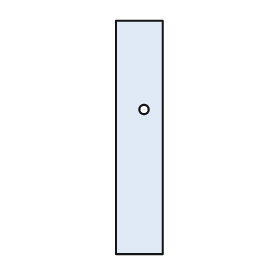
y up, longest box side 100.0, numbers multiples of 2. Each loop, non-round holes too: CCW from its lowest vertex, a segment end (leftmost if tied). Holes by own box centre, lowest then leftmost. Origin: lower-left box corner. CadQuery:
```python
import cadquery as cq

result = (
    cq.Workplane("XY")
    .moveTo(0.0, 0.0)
    .lineTo(20.0, 0.0)
    .lineTo(20.0, 100.0)
    .lineTo(0.0, 100.0)
    .close()
    .moveTo(12.0, 62.0)
    .circle(2.0)
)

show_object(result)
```